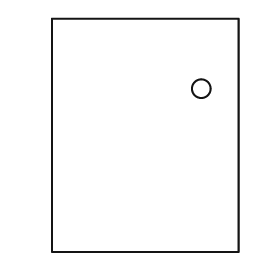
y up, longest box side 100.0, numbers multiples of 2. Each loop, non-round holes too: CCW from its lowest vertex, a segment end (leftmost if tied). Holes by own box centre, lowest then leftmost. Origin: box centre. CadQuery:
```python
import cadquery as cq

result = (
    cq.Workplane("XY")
    .moveTo(-40.0, -50.0)
    .lineTo(40.0, -50.0)
    .lineTo(40.0, 50.0)
    .lineTo(-40.0, 50.0)
    .close()
    .moveTo(24.0, 20.0)
    .circle(4.0)
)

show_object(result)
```